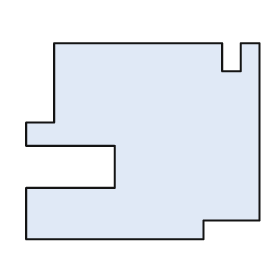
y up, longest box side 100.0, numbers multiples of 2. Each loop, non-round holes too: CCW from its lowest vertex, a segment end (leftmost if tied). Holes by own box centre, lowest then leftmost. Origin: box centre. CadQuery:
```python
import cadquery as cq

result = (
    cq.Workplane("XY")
    .moveTo(-50.0, -42.0)
    .lineTo(26.0, -42.0)
    .lineTo(26.0, -34.0)
    .lineTo(50.0, -34.0)
    .lineTo(50.0, 42.0)
    .lineTo(42.0, 42.0)
    .lineTo(42.0, 30.0)
    .lineTo(34.0, 30.0)
    .lineTo(34.0, 42.0)
    .lineTo(-38.0, 42.0)
    .lineTo(-38.0, 8.0)
    .lineTo(-50.0, 8.0)
    .lineTo(-50.0, -2.0)
    .lineTo(-12.0, -2.0)
    .lineTo(-12.0, -20.0)
    .lineTo(-50.0, -20.0)
    .close()
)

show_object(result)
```